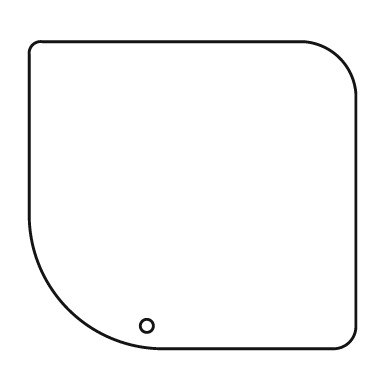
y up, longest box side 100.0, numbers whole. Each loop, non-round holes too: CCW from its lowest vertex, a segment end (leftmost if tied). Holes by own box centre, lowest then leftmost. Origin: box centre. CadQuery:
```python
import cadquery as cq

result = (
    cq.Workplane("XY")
    .moveTo(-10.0, -47.0)
    .lineTo(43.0, -47.0)
    .threePointArc((48.0, -45.0), (50.0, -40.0))
    .lineTo(50.0, 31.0)
    .threePointArc((45.0, 42.0), (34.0, 47.0))
    .lineTo(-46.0, 47.0)
    .threePointArc((-49.0, 46.0), (-50.0, 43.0))
    .lineTo(-50.0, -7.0)
    .threePointArc((-38.0, -35.0), (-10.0, -47.0))
    .close()
    .moveTo(-14.0, -40.0)
    .circle(2.0)
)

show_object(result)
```